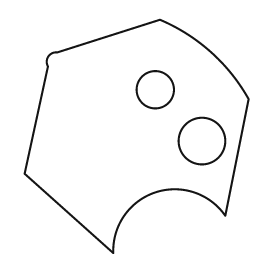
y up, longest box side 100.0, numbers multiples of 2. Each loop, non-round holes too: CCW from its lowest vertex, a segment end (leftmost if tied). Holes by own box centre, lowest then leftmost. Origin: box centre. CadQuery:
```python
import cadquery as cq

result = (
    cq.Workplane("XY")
    .moveTo(-10.0, -50.0)
    .threePointArc((8.0, -24.0), (38.0, -34.0))
    .lineTo(48.0, 16.0)
    .threePointArc((32.0, 36.0), (10.0, 50.0))
    .lineTo(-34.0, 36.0)
    .threePointArc((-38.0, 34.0), (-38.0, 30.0))
    .lineTo(-48.0, -16.0)
    .close()
    .moveTo(28.0, -2.0)
    .circle(10.0)
    .moveTo(8.0, 20.0)
    .circle(8.0)
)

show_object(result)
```